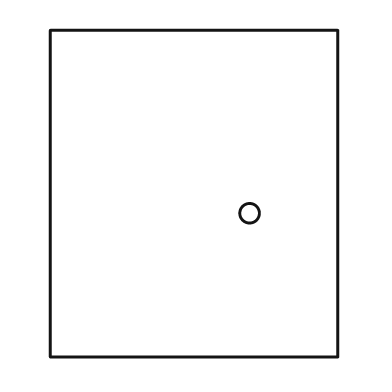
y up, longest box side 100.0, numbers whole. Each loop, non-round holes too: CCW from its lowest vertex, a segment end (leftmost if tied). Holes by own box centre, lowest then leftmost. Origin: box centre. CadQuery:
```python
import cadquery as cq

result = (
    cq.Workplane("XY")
    .moveTo(-44.0, -50.0)
    .lineTo(44.0, -50.0)
    .lineTo(44.0, 50.0)
    .lineTo(-44.0, 50.0)
    .close()
    .moveTo(17.0, -6.0)
    .circle(3.0)
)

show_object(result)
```